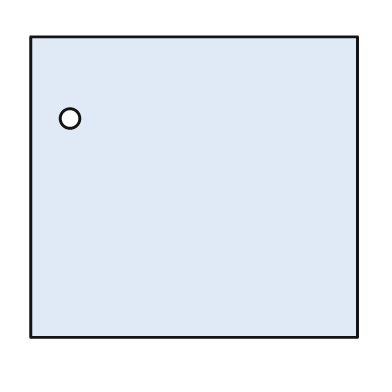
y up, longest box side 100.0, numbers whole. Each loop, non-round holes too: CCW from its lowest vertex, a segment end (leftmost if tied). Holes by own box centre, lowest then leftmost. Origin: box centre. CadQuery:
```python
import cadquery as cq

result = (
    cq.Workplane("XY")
    .moveTo(-50.0, -46.0)
    .lineTo(50.0, -46.0)
    .lineTo(50.0, 46.0)
    .lineTo(-50.0, 46.0)
    .close()
    .moveTo(-38.0, 21.0)
    .circle(3.0)
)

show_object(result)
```